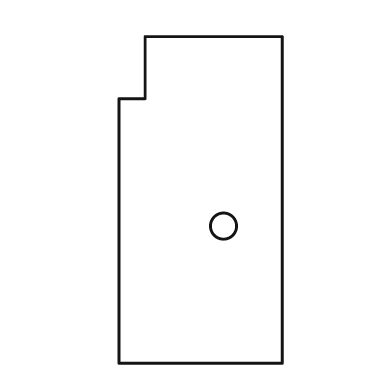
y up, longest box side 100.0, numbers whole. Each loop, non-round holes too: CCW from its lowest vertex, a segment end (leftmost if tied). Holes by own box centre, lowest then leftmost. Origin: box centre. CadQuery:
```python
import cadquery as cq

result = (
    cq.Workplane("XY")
    .moveTo(-25.0, -50.0)
    .lineTo(25.0, -50.0)
    .lineTo(25.0, 50.0)
    .lineTo(-17.0, 50.0)
    .lineTo(-17.0, 31.0)
    .lineTo(-25.0, 31.0)
    .close()
    .moveTo(7.0, -8.0)
    .circle(4.0)
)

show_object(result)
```